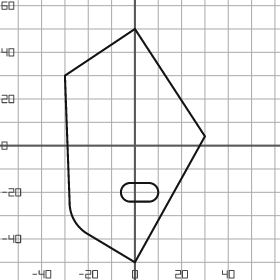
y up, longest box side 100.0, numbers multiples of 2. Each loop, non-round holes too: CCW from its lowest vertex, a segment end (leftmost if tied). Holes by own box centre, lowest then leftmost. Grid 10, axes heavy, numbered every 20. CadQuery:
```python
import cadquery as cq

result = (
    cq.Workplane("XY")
    .moveTo(0.0, -50.0)
    .lineTo(30.0, 4.0)
    .lineTo(0.0, 50.0)
    .lineTo(-30.0, 30.0)
    .lineTo(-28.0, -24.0)
    .threePointArc((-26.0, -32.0), (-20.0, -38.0))
    .close()
    .moveTo(-2.0, -24.0)
    .lineTo(6.0, -24.0)
    .threePointArc((10.0, -20.0), (6.0, -16.0))
    .lineTo(-2.0, -16.0)
    .threePointArc((-6.0, -20.0), (-2.0, -24.0))
    .close()
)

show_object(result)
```